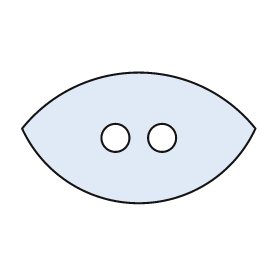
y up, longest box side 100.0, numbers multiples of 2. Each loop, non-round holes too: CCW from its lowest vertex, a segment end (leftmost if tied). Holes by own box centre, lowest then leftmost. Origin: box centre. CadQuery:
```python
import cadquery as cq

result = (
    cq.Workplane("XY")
    .moveTo(-50.0, 4.0)
    .threePointArc((0.0, -28.0), (50.0, 4.0))
    .threePointArc((0.0, 28.0), (-50.0, 4.0))
    .close()
    .moveTo(-10.0, 0.0)
    .circle(6.0)
    .moveTo(10.0, 0.0)
    .circle(6.0)
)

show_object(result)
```